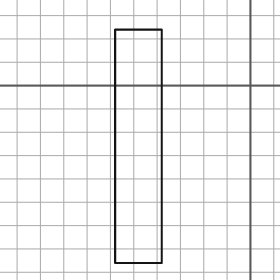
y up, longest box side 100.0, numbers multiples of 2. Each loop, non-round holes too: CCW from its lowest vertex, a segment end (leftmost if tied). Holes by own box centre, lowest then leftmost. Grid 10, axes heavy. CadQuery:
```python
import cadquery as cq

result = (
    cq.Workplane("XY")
    .moveTo(-58.0, -76.0)
    .lineTo(-38.0, -76.0)
    .lineTo(-38.0, 24.0)
    .lineTo(-58.0, 24.0)
    .close()
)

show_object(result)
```